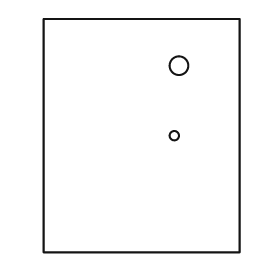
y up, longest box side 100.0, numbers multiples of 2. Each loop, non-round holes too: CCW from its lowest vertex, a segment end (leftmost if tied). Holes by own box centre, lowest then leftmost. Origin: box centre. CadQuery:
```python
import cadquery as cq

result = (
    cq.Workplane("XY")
    .moveTo(-42.0, -50.0)
    .lineTo(42.0, -50.0)
    .lineTo(42.0, 50.0)
    .lineTo(-42.0, 50.0)
    .close()
    .moveTo(14.0, 0.0)
    .circle(2.0)
    .moveTo(16.0, 30.0)
    .circle(4.0)
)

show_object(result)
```